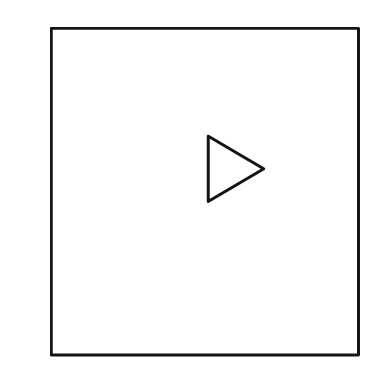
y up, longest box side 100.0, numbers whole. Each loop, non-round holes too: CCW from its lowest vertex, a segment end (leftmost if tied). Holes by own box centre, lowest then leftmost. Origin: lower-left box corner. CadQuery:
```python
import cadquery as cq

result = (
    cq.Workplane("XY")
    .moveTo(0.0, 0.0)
    .lineTo(94.0, 0.0)
    .lineTo(94.0, 100.0)
    .lineTo(0.0, 100.0)
    .close()
    .moveTo(48.0, 47.0)
    .lineTo(65.0, 57.0)
    .lineTo(48.0, 67.0)
    .close()
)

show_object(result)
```